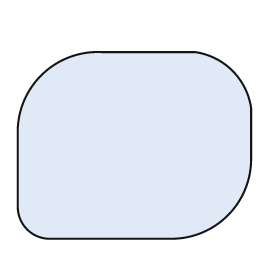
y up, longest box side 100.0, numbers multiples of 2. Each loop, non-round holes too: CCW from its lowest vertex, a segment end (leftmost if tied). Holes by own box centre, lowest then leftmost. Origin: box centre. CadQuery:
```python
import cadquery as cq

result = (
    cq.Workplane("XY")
    .moveTo(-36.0, -40.0)
    .lineTo(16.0, -40.0)
    .threePointArc((40.0, -30.0), (50.0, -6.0))
    .lineTo(50.0, 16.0)
    .threePointArc((42.0, 32.0), (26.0, 40.0))
    .lineTo(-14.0, 40.0)
    .threePointArc((-40.0, 30.0), (-50.0, 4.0))
    .lineTo(-50.0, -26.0)
    .threePointArc((-46.0, -36.0), (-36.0, -40.0))
    .close()
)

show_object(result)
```